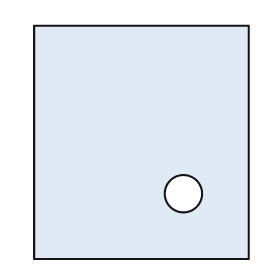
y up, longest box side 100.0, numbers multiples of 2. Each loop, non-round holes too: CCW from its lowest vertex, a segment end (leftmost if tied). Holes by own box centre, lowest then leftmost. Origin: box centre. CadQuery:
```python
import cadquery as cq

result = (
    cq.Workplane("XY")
    .moveTo(-46.0, -50.0)
    .lineTo(46.0, -50.0)
    .lineTo(46.0, 50.0)
    .lineTo(-46.0, 50.0)
    .close()
    .moveTo(18.0, -22.0)
    .circle(8.0)
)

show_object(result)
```